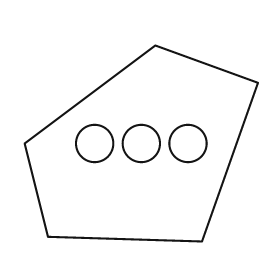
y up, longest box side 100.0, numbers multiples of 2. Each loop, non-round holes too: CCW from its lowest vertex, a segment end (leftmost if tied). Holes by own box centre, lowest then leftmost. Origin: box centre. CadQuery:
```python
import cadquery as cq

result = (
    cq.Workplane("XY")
    .moveTo(26.0, -42.0)
    .lineTo(50.0, 26.0)
    .lineTo(6.0, 42.0)
    .lineTo(-50.0, 0.0)
    .lineTo(-40.0, -40.0)
    .close()
    .moveTo(-20.0, 0.0)
    .circle(8.0)
    .moveTo(0.0, 0.0)
    .circle(8.0)
    .moveTo(20.0, 0.0)
    .circle(8.0)
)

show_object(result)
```